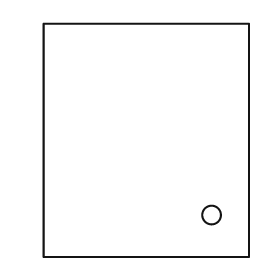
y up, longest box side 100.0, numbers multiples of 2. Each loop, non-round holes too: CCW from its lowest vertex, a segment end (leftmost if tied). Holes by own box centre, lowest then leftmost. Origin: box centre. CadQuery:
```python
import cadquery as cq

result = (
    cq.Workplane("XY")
    .moveTo(-44.0, -50.0)
    .lineTo(44.0, -50.0)
    .lineTo(44.0, 50.0)
    .lineTo(-44.0, 50.0)
    .close()
    .moveTo(28.0, -32.0)
    .circle(4.0)
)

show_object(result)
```